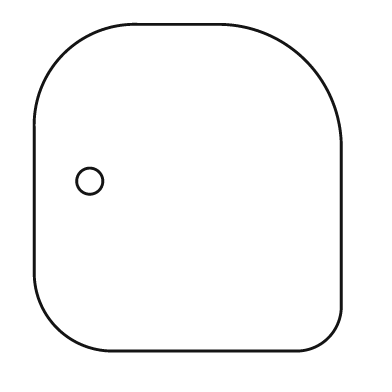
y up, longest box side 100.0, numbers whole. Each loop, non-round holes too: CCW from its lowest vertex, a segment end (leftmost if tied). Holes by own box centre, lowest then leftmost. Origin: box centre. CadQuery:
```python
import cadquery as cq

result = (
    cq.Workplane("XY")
    .moveTo(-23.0, -50.0)
    .lineTo(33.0, -50.0)
    .threePointArc((43.0, -46.0), (47.0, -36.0))
    .lineTo(47.0, 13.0)
    .threePointArc((36.0, 39.0), (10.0, 50.0))
    .lineTo(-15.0, 50.0)
    .threePointArc((-38.0, 41.0), (-47.0, 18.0))
    .lineTo(-47.0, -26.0)
    .threePointArc((-40.0, -43.0), (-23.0, -50.0))
    .close()
    .moveTo(-30.0, 2.0)
    .circle(4.0)
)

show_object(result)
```